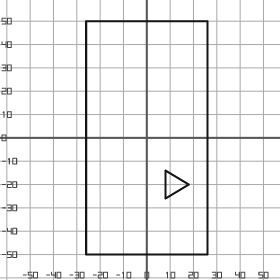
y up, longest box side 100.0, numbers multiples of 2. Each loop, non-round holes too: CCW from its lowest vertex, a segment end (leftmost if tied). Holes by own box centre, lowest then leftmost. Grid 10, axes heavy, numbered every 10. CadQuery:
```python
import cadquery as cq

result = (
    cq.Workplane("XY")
    .moveTo(-26.0, -50.0)
    .lineTo(26.0, -50.0)
    .lineTo(26.0, 50.0)
    .lineTo(-26.0, 50.0)
    .close()
    .moveTo(8.0, -26.0)
    .lineTo(18.0, -20.0)
    .lineTo(8.0, -14.0)
    .close()
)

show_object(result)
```